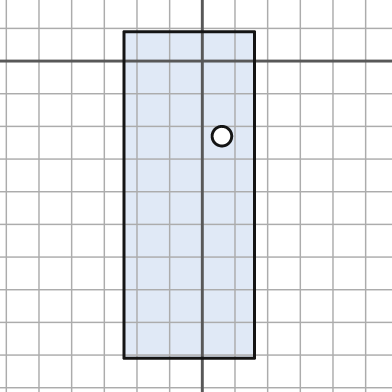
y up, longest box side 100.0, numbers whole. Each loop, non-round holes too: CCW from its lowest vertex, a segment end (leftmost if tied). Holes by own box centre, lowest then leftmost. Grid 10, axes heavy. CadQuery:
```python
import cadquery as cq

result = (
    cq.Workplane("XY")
    .moveTo(-24.0, -91.0)
    .lineTo(16.0, -91.0)
    .lineTo(16.0, 9.0)
    .lineTo(-24.0, 9.0)
    .close()
    .moveTo(6.0, -23.0)
    .circle(3.0)
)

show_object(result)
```